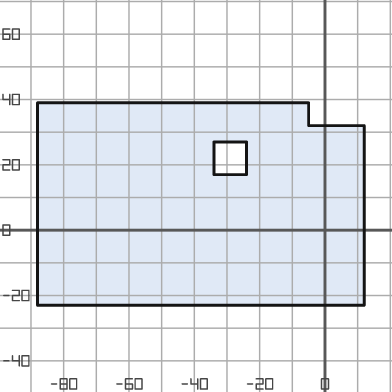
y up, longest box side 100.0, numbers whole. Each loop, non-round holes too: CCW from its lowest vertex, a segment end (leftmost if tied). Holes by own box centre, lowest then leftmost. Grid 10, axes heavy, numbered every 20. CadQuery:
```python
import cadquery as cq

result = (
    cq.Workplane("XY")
    .moveTo(-88.0, -23.0)
    .lineTo(12.0, -23.0)
    .lineTo(12.0, 32.0)
    .lineTo(-5.0, 32.0)
    .lineTo(-5.0, 39.0)
    .lineTo(-88.0, 39.0)
    .close()
    .moveTo(-34.0, 17.0)
    .lineTo(-24.0, 17.0)
    .lineTo(-24.0, 27.0)
    .lineTo(-34.0, 27.0)
    .close()
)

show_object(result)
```